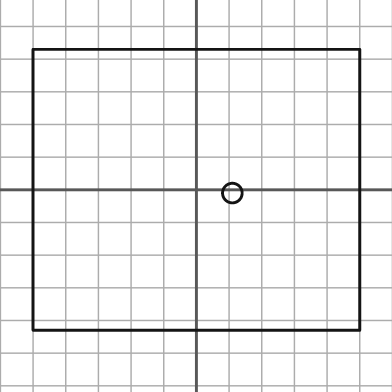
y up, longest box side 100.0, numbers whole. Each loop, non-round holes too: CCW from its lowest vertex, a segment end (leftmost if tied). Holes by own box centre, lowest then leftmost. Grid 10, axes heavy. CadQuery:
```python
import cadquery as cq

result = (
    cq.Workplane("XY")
    .moveTo(-50.0, -43.0)
    .lineTo(50.0, -43.0)
    .lineTo(50.0, 43.0)
    .lineTo(-50.0, 43.0)
    .close()
    .moveTo(11.0, -1.0)
    .circle(3.0)
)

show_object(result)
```